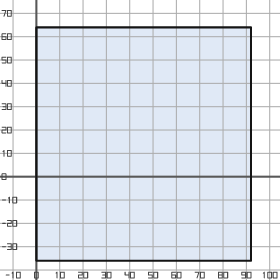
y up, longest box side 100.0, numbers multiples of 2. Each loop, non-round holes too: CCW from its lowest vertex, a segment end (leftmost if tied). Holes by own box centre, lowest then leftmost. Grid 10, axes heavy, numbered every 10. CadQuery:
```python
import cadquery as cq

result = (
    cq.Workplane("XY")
    .moveTo(0.0, -36.0)
    .lineTo(92.0, -36.0)
    .lineTo(92.0, 64.0)
    .lineTo(0.0, 64.0)
    .close()
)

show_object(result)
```